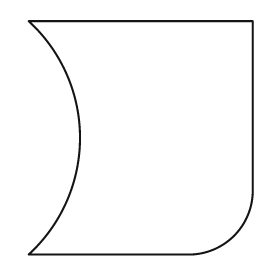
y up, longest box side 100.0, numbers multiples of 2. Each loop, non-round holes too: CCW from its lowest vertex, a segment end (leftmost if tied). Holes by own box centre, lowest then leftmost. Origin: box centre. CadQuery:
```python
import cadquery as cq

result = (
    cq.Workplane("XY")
    .moveTo(-48.0, -50.0)
    .lineTo(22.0, -50.0)
    .threePointArc((40.0, -42.0), (48.0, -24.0))
    .lineTo(48.0, 50.0)
    .lineTo(-48.0, 50.0)
    .threePointArc((-26.0, 0.0), (-48.0, -50.0))
    .close()
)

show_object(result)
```